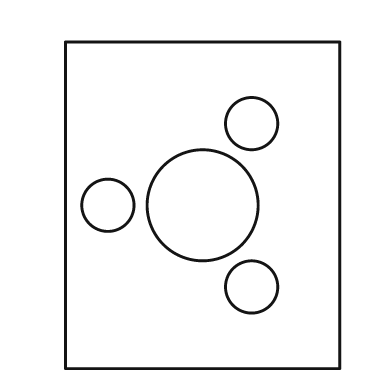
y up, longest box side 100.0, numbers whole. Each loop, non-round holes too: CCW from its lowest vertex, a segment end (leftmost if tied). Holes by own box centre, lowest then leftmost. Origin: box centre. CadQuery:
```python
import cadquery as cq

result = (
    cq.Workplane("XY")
    .moveTo(-42.0, -50.0)
    .lineTo(42.0, -50.0)
    .lineTo(42.0, 50.0)
    .lineTo(-42.0, 50.0)
    .close()
    .moveTo(15.0, -25.0)
    .circle(8.0)
    .moveTo(-29.0, 0.0)
    .circle(8.0)
    .moveTo(0.0, 0.0)
    .circle(17.0)
    .moveTo(15.0, 25.0)
    .circle(8.0)
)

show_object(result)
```